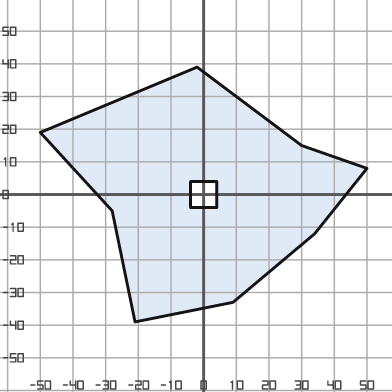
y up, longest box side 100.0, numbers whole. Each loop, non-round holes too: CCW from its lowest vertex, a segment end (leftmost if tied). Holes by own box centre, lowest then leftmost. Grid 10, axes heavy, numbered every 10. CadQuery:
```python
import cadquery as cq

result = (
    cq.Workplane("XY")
    .moveTo(-21.0, -39.0)
    .lineTo(9.0, -33.0)
    .lineTo(34.0, -12.0)
    .lineTo(50.0, 8.0)
    .lineTo(30.0, 15.0)
    .lineTo(-2.0, 39.0)
    .lineTo(-50.0, 19.0)
    .lineTo(-28.0, -5.0)
    .close()
    .moveTo(-4.0, -4.0)
    .lineTo(4.0, -4.0)
    .lineTo(4.0, 4.0)
    .lineTo(-4.0, 4.0)
    .close()
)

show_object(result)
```